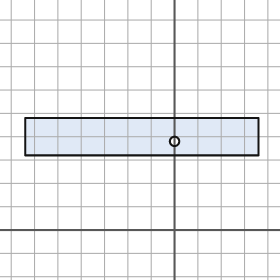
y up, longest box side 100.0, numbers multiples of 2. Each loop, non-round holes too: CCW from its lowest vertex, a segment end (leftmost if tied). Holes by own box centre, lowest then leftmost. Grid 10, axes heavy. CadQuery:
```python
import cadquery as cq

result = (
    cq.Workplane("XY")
    .moveTo(-64.0, 32.0)
    .lineTo(36.0, 32.0)
    .lineTo(36.0, 48.0)
    .lineTo(-64.0, 48.0)
    .close()
    .moveTo(0.0, 38.0)
    .circle(2.0)
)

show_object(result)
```